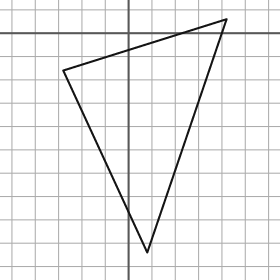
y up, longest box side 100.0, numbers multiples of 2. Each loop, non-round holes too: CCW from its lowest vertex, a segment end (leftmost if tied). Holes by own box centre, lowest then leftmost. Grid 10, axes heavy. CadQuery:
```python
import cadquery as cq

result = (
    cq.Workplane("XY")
    .moveTo(8.0, -94.0)
    .lineTo(42.0, 6.0)
    .lineTo(-28.0, -16.0)
    .close()
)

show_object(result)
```